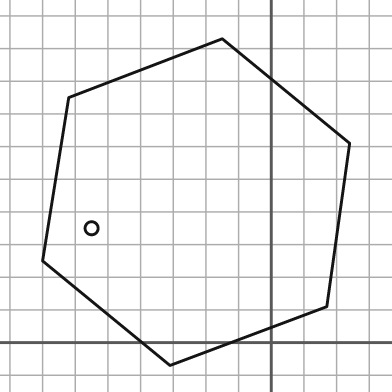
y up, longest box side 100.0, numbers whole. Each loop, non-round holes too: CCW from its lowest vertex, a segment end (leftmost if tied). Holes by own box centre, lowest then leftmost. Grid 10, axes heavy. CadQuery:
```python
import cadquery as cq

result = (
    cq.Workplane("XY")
    .moveTo(-31.0, -7.0)
    .lineTo(17.0, 11.0)
    .lineTo(24.0, 61.0)
    .lineTo(-15.0, 93.0)
    .lineTo(-62.0, 75.0)
    .lineTo(-70.0, 25.0)
    .close()
    .moveTo(-55.0, 35.0)
    .circle(2.0)
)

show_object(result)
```